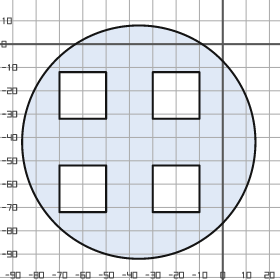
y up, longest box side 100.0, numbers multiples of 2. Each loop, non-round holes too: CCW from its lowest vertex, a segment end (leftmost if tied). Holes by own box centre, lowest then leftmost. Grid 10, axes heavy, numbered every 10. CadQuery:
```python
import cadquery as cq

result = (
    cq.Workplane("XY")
    .moveTo(-36.0, -42.0)
    .circle(50.0)
    .moveTo(-70.0, -72.0)
    .lineTo(-50.0, -72.0)
    .lineTo(-50.0, -52.0)
    .lineTo(-70.0, -52.0)
    .close()
    .moveTo(-30.0, -72.0)
    .lineTo(-10.0, -72.0)
    .lineTo(-10.0, -52.0)
    .lineTo(-30.0, -52.0)
    .close()
    .moveTo(-70.0, -32.0)
    .lineTo(-50.0, -32.0)
    .lineTo(-50.0, -12.0)
    .lineTo(-70.0, -12.0)
    .close()
    .moveTo(-30.0, -32.0)
    .lineTo(-10.0, -32.0)
    .lineTo(-10.0, -12.0)
    .lineTo(-30.0, -12.0)
    .close()
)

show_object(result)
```